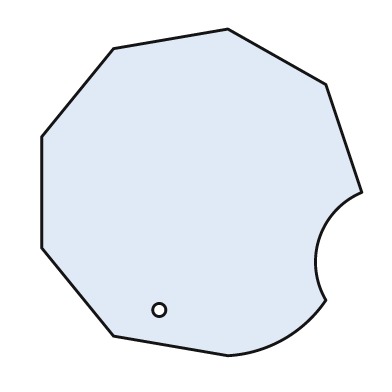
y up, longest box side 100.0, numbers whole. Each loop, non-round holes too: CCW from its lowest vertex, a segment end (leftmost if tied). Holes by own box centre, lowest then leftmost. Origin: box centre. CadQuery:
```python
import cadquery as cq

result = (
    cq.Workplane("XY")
    .moveTo(8.0, -50.0)
    .threePointArc((25.0, -45.0), (38.0, -33.0))
    .threePointArc((36.0, -14.0), (49.0, 0.0))
    .lineTo(38.0, 33.0)
    .lineTo(8.0, 50.0)
    .lineTo(-27.0, 44.0)
    .lineTo(-49.0, 17.0)
    .lineTo(-49.0, -17.0)
    .lineTo(-27.0, -44.0)
    .close()
    .moveTo(-13.0, -36.0)
    .circle(2.0)
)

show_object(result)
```